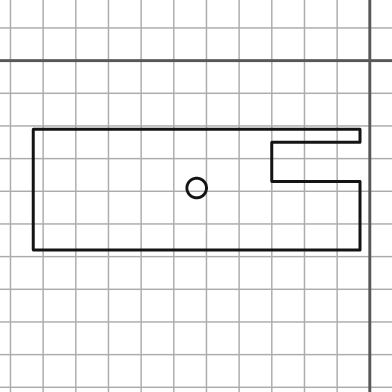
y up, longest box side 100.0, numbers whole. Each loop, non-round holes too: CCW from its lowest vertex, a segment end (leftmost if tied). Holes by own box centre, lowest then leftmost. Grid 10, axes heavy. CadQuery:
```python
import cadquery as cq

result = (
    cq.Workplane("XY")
    .moveTo(-103.0, -58.0)
    .lineTo(-3.0, -58.0)
    .lineTo(-3.0, -37.0)
    .lineTo(-30.0, -37.0)
    .lineTo(-30.0, -25.0)
    .lineTo(-3.0, -25.0)
    .lineTo(-3.0, -21.0)
    .lineTo(-103.0, -21.0)
    .close()
    .moveTo(-53.0, -39.0)
    .circle(3.0)
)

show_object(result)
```